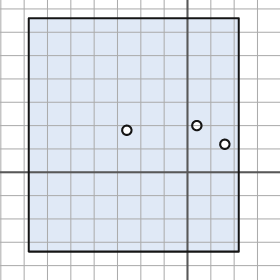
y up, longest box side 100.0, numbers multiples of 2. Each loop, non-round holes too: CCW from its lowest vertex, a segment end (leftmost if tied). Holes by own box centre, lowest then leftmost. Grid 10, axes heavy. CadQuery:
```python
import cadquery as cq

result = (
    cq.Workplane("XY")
    .moveTo(-68.0, -34.0)
    .lineTo(22.0, -34.0)
    .lineTo(22.0, 66.0)
    .lineTo(-68.0, 66.0)
    .close()
    .moveTo(16.0, 12.0)
    .circle(2.0)
    .moveTo(-26.0, 18.0)
    .circle(2.0)
    .moveTo(4.0, 20.0)
    .circle(2.0)
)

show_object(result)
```